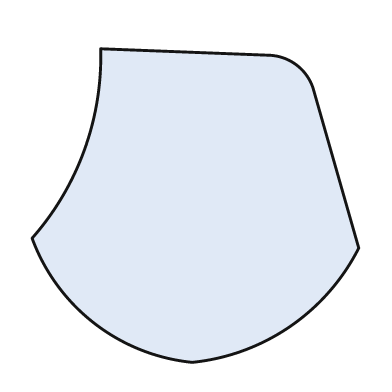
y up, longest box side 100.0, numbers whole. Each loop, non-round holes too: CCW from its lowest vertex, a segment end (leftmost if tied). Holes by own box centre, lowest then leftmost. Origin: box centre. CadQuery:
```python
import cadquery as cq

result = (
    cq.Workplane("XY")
    .moveTo(-1.0, -48.0)
    .threePointArc((29.0, -37.0), (50.0, -13.0))
    .lineTo(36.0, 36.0)
    .threePointArc((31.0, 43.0), (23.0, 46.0))
    .lineTo(-29.0, 48.0)
    .threePointArc((-34.0, 17.0), (-50.0, -10.0))
    .threePointArc((-31.0, -36.0), (-1.0, -48.0))
    .close()
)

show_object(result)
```